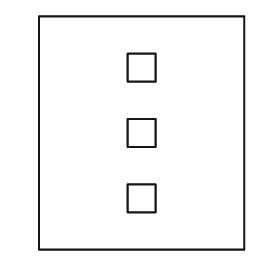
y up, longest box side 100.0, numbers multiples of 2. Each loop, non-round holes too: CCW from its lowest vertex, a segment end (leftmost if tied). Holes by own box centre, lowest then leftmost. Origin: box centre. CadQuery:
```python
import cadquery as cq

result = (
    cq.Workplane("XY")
    .moveTo(-44.0, -50.0)
    .lineTo(44.0, -50.0)
    .lineTo(44.0, 50.0)
    .lineTo(-44.0, 50.0)
    .close()
    .moveTo(-6.0, -34.0)
    .lineTo(6.0, -34.0)
    .lineTo(6.0, -22.0)
    .lineTo(-6.0, -22.0)
    .close()
    .moveTo(-6.0, -6.0)
    .lineTo(6.0, -6.0)
    .lineTo(6.0, 6.0)
    .lineTo(-6.0, 6.0)
    .close()
    .moveTo(-6.0, 22.0)
    .lineTo(6.0, 22.0)
    .lineTo(6.0, 34.0)
    .lineTo(-6.0, 34.0)
    .close()
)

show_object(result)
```